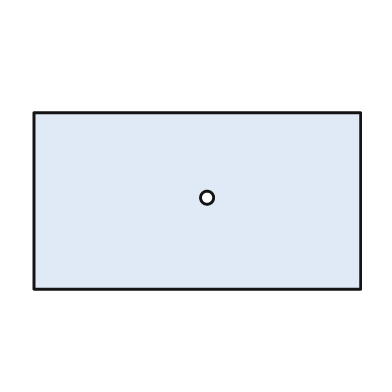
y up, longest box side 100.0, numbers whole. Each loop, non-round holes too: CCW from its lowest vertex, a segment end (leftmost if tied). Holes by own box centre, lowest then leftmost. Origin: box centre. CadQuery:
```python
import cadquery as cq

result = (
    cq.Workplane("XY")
    .moveTo(-50.0, -27.0)
    .lineTo(50.0, -27.0)
    .lineTo(50.0, 27.0)
    .lineTo(-50.0, 27.0)
    .close()
    .moveTo(3.0, 1.0)
    .circle(2.0)
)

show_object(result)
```